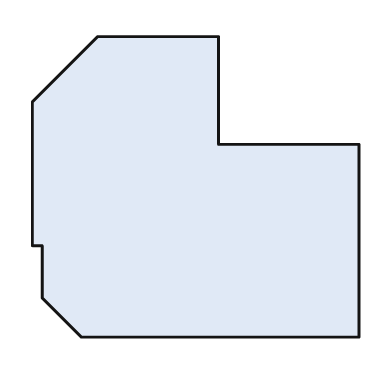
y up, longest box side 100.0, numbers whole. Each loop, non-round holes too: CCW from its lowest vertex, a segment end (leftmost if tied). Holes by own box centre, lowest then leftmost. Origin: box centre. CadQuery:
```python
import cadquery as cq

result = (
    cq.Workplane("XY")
    .moveTo(-35.0, -46.0)
    .lineTo(50.0, -46.0)
    .lineTo(50.0, 13.0)
    .lineTo(7.0, 13.0)
    .lineTo(7.0, 46.0)
    .lineTo(-30.0, 46.0)
    .lineTo(-50.0, 26.0)
    .lineTo(-50.0, -18.0)
    .lineTo(-47.0, -18.0)
    .lineTo(-47.0, -34.0)
    .close()
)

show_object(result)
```